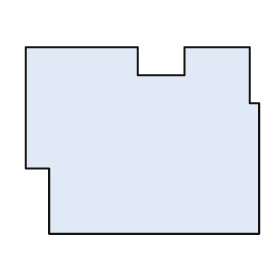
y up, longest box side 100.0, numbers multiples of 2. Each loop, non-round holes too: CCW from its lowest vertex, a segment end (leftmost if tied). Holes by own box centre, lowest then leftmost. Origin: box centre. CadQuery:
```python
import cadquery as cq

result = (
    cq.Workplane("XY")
    .moveTo(-40.0, -40.0)
    .lineTo(50.0, -40.0)
    .lineTo(50.0, 16.0)
    .lineTo(46.0, 16.0)
    .lineTo(46.0, 40.0)
    .lineTo(18.0, 40.0)
    .lineTo(18.0, 28.0)
    .lineTo(-2.0, 28.0)
    .lineTo(-2.0, 40.0)
    .lineTo(-50.0, 40.0)
    .lineTo(-50.0, -12.0)
    .lineTo(-40.0, -12.0)
    .close()
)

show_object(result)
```